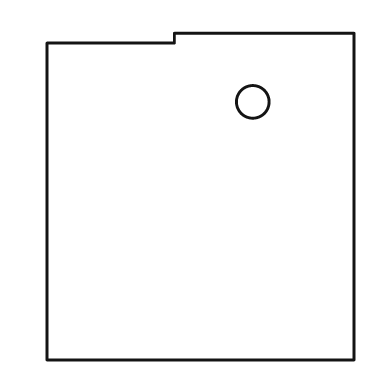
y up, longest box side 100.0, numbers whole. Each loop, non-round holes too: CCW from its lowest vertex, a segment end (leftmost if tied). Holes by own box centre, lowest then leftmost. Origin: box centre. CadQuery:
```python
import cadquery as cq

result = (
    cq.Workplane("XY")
    .moveTo(-47.0, -50.0)
    .lineTo(47.0, -50.0)
    .lineTo(47.0, 50.0)
    .lineTo(-8.0, 50.0)
    .lineTo(-8.0, 47.0)
    .lineTo(-47.0, 47.0)
    .close()
    .moveTo(16.0, 29.0)
    .circle(5.0)
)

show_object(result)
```